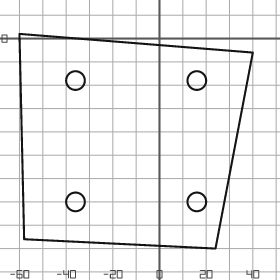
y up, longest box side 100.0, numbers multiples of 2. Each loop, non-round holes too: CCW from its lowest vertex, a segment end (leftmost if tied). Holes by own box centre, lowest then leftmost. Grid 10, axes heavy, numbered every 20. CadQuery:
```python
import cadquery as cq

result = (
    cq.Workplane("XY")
    .moveTo(24.0, -90.0)
    .lineTo(40.0, -6.0)
    .lineTo(-60.0, 2.0)
    .lineTo(-58.0, -86.0)
    .close()
    .moveTo(-36.0, -70.0)
    .circle(4.0)
    .moveTo(16.0, -70.0)
    .circle(4.0)
    .moveTo(-36.0, -18.0)
    .circle(4.0)
    .moveTo(16.0, -18.0)
    .circle(4.0)
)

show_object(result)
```